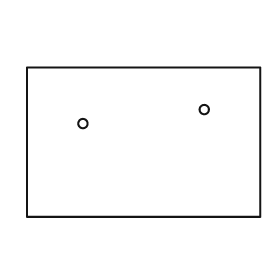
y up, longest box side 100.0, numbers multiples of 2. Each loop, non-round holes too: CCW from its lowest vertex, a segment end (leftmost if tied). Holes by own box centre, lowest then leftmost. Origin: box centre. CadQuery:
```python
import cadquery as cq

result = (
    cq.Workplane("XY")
    .moveTo(-50.0, -32.0)
    .lineTo(50.0, -32.0)
    .lineTo(50.0, 32.0)
    .lineTo(-50.0, 32.0)
    .close()
    .moveTo(-26.0, 8.0)
    .circle(2.0)
    .moveTo(26.0, 14.0)
    .circle(2.0)
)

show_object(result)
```